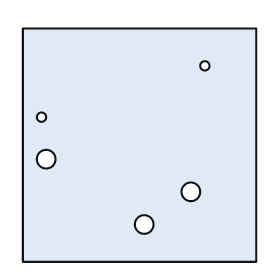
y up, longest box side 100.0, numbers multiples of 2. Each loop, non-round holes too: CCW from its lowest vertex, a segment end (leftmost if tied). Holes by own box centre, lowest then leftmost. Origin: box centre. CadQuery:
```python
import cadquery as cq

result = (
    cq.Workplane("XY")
    .moveTo(-50.0, -50.0)
    .lineTo(50.0, -50.0)
    .lineTo(50.0, 50.0)
    .lineTo(-50.0, 50.0)
    .close()
    .moveTo(2.0, -34.0)
    .circle(4.0)
    .moveTo(22.0, -20.0)
    .circle(4.0)
    .moveTo(-40.0, -6.0)
    .circle(4.0)
    .moveTo(-42.0, 12.0)
    .circle(2.0)
    .moveTo(28.0, 34.0)
    .circle(2.0)
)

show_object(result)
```